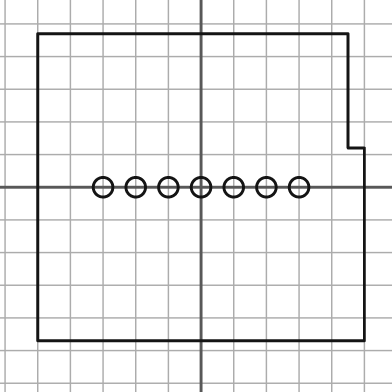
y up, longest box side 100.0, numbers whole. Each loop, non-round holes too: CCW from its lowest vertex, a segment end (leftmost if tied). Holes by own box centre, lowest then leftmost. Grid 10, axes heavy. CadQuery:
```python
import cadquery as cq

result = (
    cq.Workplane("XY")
    .moveTo(-50.0, -47.0)
    .lineTo(50.0, -47.0)
    .lineTo(50.0, 12.0)
    .lineTo(45.0, 12.0)
    .lineTo(45.0, 47.0)
    .lineTo(-50.0, 47.0)
    .close()
    .moveTo(-30.0, 0.0)
    .circle(3.0)
    .moveTo(-20.0, 0.0)
    .circle(3.0)
    .moveTo(-10.0, 0.0)
    .circle(3.0)
    .moveTo(0.0, 0.0)
    .circle(3.0)
    .moveTo(10.0, 0.0)
    .circle(3.0)
    .moveTo(20.0, 0.0)
    .circle(3.0)
    .moveTo(30.0, 0.0)
    .circle(3.0)
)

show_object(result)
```